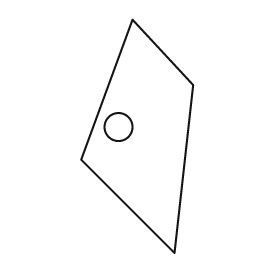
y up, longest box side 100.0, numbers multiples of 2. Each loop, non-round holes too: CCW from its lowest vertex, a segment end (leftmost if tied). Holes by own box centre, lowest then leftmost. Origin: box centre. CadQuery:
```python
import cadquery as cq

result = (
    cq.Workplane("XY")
    .moveTo(16.0, -50.0)
    .lineTo(24.0, 22.0)
    .lineTo(-2.0, 50.0)
    .lineTo(-24.0, -10.0)
    .close()
    .moveTo(-8.0, 4.0)
    .circle(6.0)
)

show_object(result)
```